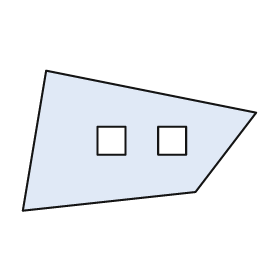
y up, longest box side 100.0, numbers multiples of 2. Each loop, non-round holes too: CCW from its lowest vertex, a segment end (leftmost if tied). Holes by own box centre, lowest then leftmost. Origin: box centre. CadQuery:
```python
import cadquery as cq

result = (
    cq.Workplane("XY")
    .moveTo(-50.0, -30.0)
    .lineTo(24.0, -22.0)
    .lineTo(50.0, 12.0)
    .lineTo(-40.0, 30.0)
    .close()
    .moveTo(-18.0, -6.0)
    .lineTo(-6.0, -6.0)
    .lineTo(-6.0, 6.0)
    .lineTo(-18.0, 6.0)
    .close()
    .moveTo(8.0, -6.0)
    .lineTo(20.0, -6.0)
    .lineTo(20.0, 6.0)
    .lineTo(8.0, 6.0)
    .close()
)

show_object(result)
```